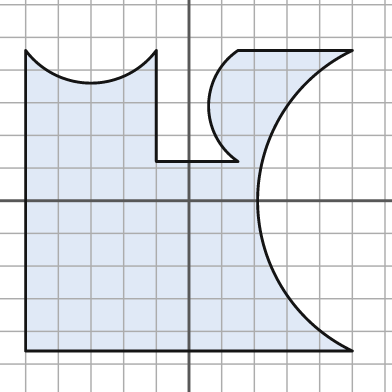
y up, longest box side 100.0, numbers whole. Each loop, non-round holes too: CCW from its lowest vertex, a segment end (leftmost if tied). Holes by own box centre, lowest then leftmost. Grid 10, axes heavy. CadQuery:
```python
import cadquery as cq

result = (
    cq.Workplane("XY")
    .moveTo(-50.0, -46.0)
    .lineTo(50.0, -46.0)
    .threePointArc((21.0, 0.0), (50.0, 46.0))
    .lineTo(15.0, 46.0)
    .threePointArc((6.0, 29.0), (15.0, 12.0))
    .lineTo(-10.0, 12.0)
    .lineTo(-10.0, 46.0)
    .threePointArc((-30.0, 36.0), (-50.0, 46.0))
    .close()
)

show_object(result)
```